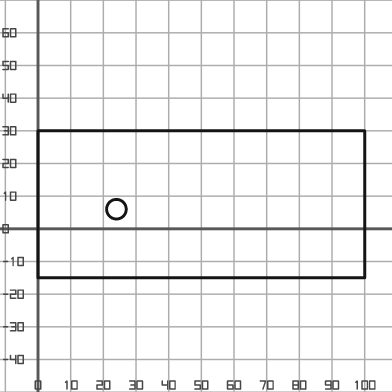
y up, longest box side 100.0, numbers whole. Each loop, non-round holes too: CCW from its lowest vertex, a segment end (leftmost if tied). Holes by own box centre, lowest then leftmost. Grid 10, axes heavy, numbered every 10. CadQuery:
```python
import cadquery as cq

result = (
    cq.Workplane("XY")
    .moveTo(0.0, -15.0)
    .lineTo(100.0, -15.0)
    .lineTo(100.0, 30.0)
    .lineTo(0.0, 30.0)
    .close()
    .moveTo(24.0, 6.0)
    .circle(3.0)
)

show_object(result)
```